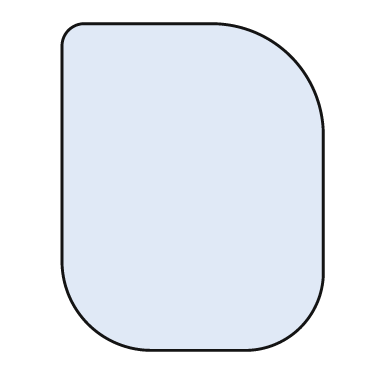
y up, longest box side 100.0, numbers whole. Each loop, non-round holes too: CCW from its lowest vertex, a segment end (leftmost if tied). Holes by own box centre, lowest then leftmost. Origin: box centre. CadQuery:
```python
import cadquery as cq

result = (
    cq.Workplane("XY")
    .moveTo(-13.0, -50.0)
    .lineTo(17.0, -50.0)
    .threePointArc((33.0, -43.0), (40.0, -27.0))
    .lineTo(40.0, 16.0)
    .threePointArc((30.0, 40.0), (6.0, 50.0))
    .lineTo(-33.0, 50.0)
    .threePointArc((-38.0, 48.0), (-40.0, 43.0))
    .lineTo(-40.0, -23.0)
    .threePointArc((-32.0, -42.0), (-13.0, -50.0))
    .close()
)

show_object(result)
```